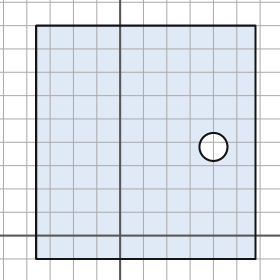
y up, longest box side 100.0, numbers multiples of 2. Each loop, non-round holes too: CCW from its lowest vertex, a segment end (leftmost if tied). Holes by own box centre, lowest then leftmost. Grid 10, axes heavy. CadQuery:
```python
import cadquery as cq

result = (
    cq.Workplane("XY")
    .moveTo(-36.0, -10.0)
    .lineTo(58.0, -10.0)
    .lineTo(58.0, 90.0)
    .lineTo(-36.0, 90.0)
    .close()
    .moveTo(40.0, 38.0)
    .circle(6.0)
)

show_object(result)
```